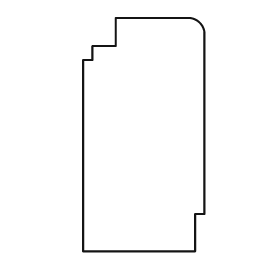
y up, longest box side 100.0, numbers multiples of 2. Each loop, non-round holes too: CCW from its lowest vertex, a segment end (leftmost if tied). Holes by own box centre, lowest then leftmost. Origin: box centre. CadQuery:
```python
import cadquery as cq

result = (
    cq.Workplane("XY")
    .moveTo(-26.0, -50.0)
    .lineTo(22.0, -50.0)
    .lineTo(22.0, -34.0)
    .lineTo(26.0, -34.0)
    .lineTo(26.0, 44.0)
    .threePointArc((24.0, 48.0), (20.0, 50.0))
    .lineTo(-12.0, 50.0)
    .lineTo(-12.0, 38.0)
    .lineTo(-22.0, 38.0)
    .lineTo(-22.0, 32.0)
    .lineTo(-26.0, 32.0)
    .close()
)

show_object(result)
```